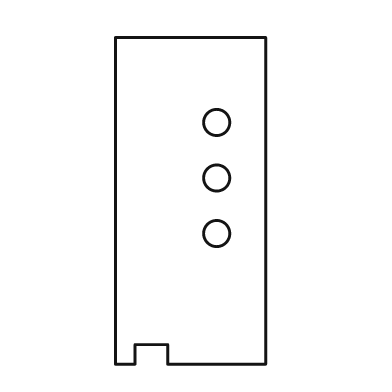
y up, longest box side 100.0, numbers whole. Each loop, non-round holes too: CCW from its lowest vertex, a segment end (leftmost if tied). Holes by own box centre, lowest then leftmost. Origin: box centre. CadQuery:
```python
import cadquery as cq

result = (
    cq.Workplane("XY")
    .moveTo(-23.0, -50.0)
    .lineTo(-17.0, -50.0)
    .lineTo(-17.0, -44.0)
    .lineTo(-7.0, -44.0)
    .lineTo(-7.0, -50.0)
    .lineTo(23.0, -50.0)
    .lineTo(23.0, 50.0)
    .lineTo(-23.0, 50.0)
    .close()
    .moveTo(8.0, -10.0)
    .circle(4.0)
    .moveTo(8.0, 7.0)
    .circle(4.0)
    .moveTo(8.0, 24.0)
    .circle(4.0)
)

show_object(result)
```